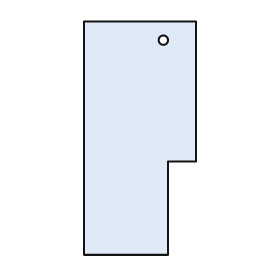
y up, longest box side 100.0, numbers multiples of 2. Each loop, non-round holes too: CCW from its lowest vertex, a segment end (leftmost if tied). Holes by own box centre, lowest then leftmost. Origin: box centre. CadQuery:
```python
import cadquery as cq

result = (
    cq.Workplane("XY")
    .moveTo(-24.0, -50.0)
    .lineTo(12.0, -50.0)
    .lineTo(12.0, -10.0)
    .lineTo(24.0, -10.0)
    .lineTo(24.0, 50.0)
    .lineTo(-24.0, 50.0)
    .close()
    .moveTo(10.0, 42.0)
    .circle(2.0)
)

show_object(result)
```